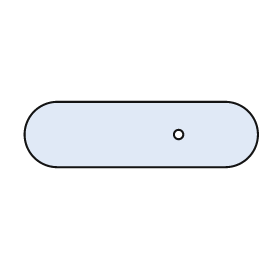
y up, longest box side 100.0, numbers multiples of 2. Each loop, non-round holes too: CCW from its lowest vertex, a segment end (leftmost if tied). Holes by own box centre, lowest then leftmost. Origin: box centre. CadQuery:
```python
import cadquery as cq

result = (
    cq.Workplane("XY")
    .moveTo(-36.0, -14.0)
    .lineTo(36.0, -14.0)
    .threePointArc((50.0, 0.0), (36.0, 14.0))
    .lineTo(-36.0, 14.0)
    .threePointArc((-50.0, 0.0), (-36.0, -14.0))
    .close()
    .moveTo(16.0, 0.0)
    .circle(2.0)
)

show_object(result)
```